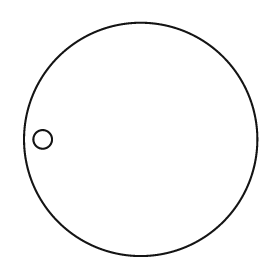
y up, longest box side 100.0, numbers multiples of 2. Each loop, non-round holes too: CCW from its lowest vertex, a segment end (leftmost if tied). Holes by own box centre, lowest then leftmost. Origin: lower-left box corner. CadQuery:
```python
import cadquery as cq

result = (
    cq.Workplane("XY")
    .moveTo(50.0, 50.0)
    .circle(50.0)
    .moveTo(8.0, 50.0)
    .circle(4.0)
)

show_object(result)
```